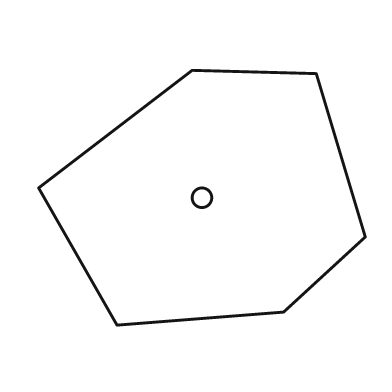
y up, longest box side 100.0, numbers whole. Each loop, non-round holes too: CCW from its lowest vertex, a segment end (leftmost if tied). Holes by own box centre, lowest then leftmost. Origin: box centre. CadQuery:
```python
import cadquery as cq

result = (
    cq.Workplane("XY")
    .moveTo(-26.0, -39.0)
    .lineTo(25.0, -35.0)
    .lineTo(50.0, -12.0)
    .lineTo(35.0, 38.0)
    .lineTo(-3.0, 39.0)
    .lineTo(-50.0, 3.0)
    .close()
    .moveTo(0.0, 0.0)
    .circle(3.0)
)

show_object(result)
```